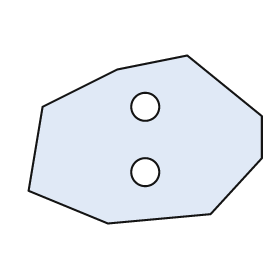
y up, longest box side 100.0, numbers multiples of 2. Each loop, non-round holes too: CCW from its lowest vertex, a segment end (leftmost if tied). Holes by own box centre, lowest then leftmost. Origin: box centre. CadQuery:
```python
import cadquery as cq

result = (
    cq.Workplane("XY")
    .moveTo(-16.0, -36.0)
    .lineTo(28.0, -32.0)
    .lineTo(50.0, -8.0)
    .lineTo(50.0, 10.0)
    .lineTo(18.0, 36.0)
    .lineTo(-12.0, 30.0)
    .lineTo(-44.0, 14.0)
    .lineTo(-50.0, -22.0)
    .close()
    .moveTo(0.0, -14.0)
    .circle(6.0)
    .moveTo(0.0, 14.0)
    .circle(6.0)
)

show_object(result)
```